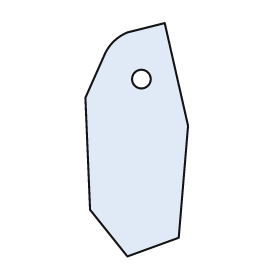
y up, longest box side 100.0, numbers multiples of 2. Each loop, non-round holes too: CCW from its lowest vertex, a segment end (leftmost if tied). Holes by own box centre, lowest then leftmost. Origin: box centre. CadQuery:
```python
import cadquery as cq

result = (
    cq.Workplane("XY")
    .moveTo(-4.0, -50.0)
    .lineTo(18.0, -42.0)
    .lineTo(22.0, 6.0)
    .lineTo(12.0, 50.0)
    .lineTo(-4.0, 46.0)
    .threePointArc((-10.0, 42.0), (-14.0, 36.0))
    .lineTo(-22.0, 18.0)
    .lineTo(-20.0, -30.0)
    .close()
    .moveTo(2.0, 26.0)
    .circle(4.0)
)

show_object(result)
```